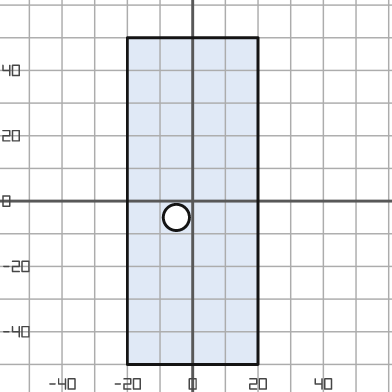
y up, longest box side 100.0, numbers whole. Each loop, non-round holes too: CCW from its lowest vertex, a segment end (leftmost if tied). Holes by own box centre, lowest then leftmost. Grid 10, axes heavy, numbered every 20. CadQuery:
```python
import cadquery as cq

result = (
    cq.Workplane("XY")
    .moveTo(-20.0, -50.0)
    .lineTo(20.0, -50.0)
    .lineTo(20.0, 50.0)
    .lineTo(-20.0, 50.0)
    .close()
    .moveTo(-5.0, -5.0)
    .circle(4.0)
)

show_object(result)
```